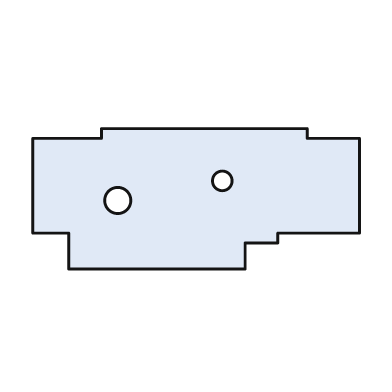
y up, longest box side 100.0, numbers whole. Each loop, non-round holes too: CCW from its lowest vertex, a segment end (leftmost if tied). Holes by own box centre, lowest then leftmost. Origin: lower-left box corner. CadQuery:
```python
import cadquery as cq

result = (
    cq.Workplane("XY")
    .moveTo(11.0, 0.0)
    .lineTo(65.0, 0.0)
    .lineTo(65.0, 8.0)
    .lineTo(75.0, 8.0)
    .lineTo(75.0, 11.0)
    .lineTo(100.0, 11.0)
    .lineTo(100.0, 40.0)
    .lineTo(84.0, 40.0)
    .lineTo(84.0, 43.0)
    .lineTo(21.0, 43.0)
    .lineTo(21.0, 40.0)
    .lineTo(0.0, 40.0)
    .lineTo(0.0, 11.0)
    .lineTo(11.0, 11.0)
    .close()
    .moveTo(26.0, 21.0)
    .circle(4.0)
    .moveTo(58.0, 27.0)
    .circle(3.0)
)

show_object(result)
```